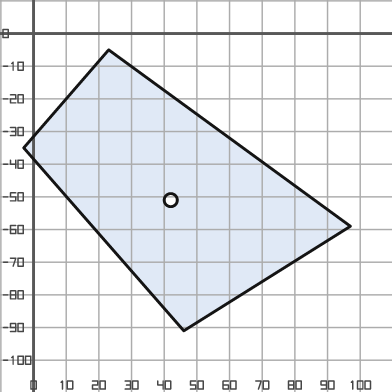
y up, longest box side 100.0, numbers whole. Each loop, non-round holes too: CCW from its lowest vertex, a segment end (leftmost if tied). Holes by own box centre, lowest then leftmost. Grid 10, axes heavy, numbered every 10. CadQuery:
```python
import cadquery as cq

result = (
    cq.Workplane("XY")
    .moveTo(46.0, -91.0)
    .lineTo(97.0, -59.0)
    .lineTo(23.0, -5.0)
    .lineTo(-3.0, -35.0)
    .close()
    .moveTo(42.0, -51.0)
    .circle(2.0)
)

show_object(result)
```